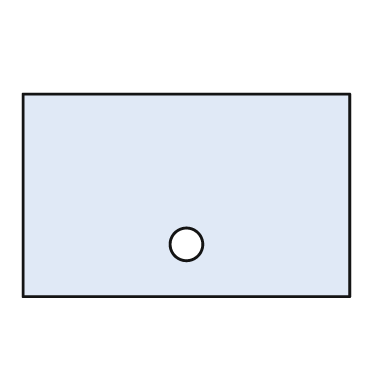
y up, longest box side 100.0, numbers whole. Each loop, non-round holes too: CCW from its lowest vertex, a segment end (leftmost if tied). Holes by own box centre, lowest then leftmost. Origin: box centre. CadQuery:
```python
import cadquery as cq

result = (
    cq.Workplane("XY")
    .moveTo(-50.0, -31.0)
    .lineTo(50.0, -31.0)
    .lineTo(50.0, 31.0)
    .lineTo(-50.0, 31.0)
    .close()
    .moveTo(0.0, -15.0)
    .circle(5.0)
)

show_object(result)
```